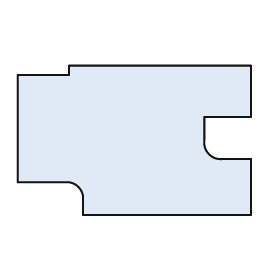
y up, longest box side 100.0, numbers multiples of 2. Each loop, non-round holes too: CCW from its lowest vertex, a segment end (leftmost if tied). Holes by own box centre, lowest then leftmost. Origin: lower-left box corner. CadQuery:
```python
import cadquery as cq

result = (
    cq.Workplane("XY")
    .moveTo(28.0, 0.0)
    .lineTo(100.0, 0.0)
    .lineTo(100.0, 24.0)
    .lineTo(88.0, 24.0)
    .threePointArc((82.0, 26.0), (80.0, 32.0))
    .lineTo(80.0, 42.0)
    .lineTo(100.0, 42.0)
    .lineTo(100.0, 64.0)
    .lineTo(22.0, 64.0)
    .lineTo(22.0, 60.0)
    .lineTo(0.0, 60.0)
    .lineTo(0.0, 14.0)
    .lineTo(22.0, 14.0)
    .threePointArc((26.0, 12.0), (28.0, 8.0))
    .close()
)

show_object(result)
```